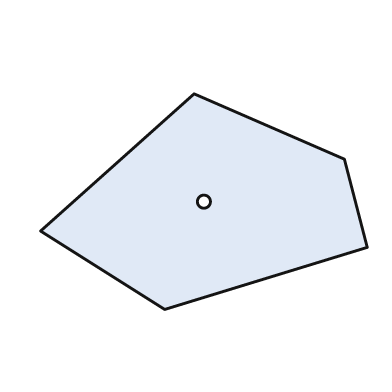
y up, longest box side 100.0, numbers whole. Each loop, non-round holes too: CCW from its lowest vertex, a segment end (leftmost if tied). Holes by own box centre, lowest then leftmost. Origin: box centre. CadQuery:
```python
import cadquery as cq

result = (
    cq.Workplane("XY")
    .moveTo(-12.0, -33.0)
    .lineTo(50.0, -14.0)
    .lineTo(43.0, 13.0)
    .lineTo(-3.0, 33.0)
    .lineTo(-50.0, -9.0)
    .close()
    .moveTo(0.0, 0.0)
    .circle(2.0)
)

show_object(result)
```